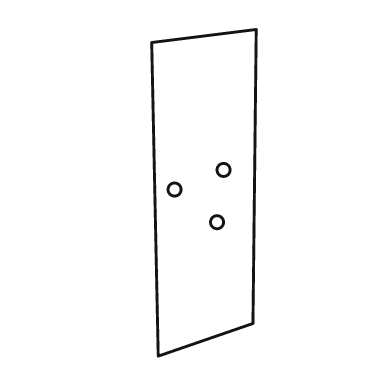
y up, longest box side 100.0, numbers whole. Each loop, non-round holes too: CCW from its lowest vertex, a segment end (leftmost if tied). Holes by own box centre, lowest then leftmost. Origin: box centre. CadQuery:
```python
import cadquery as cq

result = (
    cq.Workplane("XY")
    .moveTo(-14.0, -50.0)
    .lineTo(15.0, -40.0)
    .lineTo(16.0, 50.0)
    .lineTo(-16.0, 46.0)
    .close()
    .moveTo(4.0, -9.0)
    .circle(2.0)
    .moveTo(-9.0, 1.0)
    .circle(2.0)
    .moveTo(6.0, 7.0)
    .circle(2.0)
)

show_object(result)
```